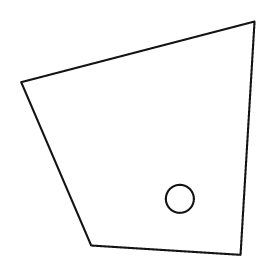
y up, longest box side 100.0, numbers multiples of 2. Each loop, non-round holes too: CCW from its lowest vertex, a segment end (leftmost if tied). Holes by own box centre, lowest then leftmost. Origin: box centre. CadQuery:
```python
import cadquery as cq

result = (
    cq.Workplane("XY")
    .moveTo(44.0, -50.0)
    .lineTo(50.0, 50.0)
    .lineTo(-50.0, 24.0)
    .lineTo(-20.0, -46.0)
    .close()
    .moveTo(18.0, -26.0)
    .circle(6.0)
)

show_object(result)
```